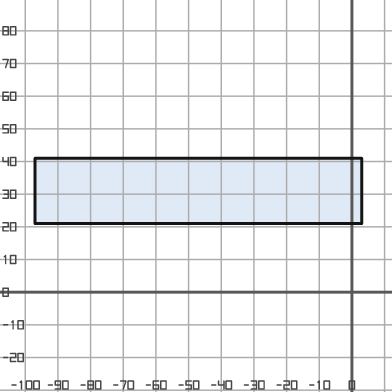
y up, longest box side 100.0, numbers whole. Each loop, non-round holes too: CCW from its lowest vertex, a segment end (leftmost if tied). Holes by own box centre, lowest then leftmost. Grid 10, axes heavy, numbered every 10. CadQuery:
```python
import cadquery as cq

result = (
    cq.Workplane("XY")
    .moveTo(-97.0, 21.0)
    .lineTo(3.0, 21.0)
    .lineTo(3.0, 41.0)
    .lineTo(-97.0, 41.0)
    .close()
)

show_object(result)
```